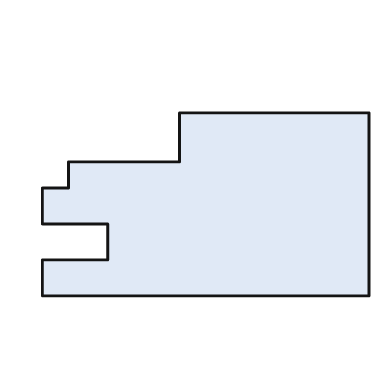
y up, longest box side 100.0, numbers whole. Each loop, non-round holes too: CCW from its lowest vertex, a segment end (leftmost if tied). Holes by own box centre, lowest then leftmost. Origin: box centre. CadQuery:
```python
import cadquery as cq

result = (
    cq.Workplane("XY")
    .moveTo(-50.0, -28.0)
    .lineTo(50.0, -28.0)
    .lineTo(50.0, 28.0)
    .lineTo(-8.0, 28.0)
    .lineTo(-8.0, 13.0)
    .lineTo(-42.0, 13.0)
    .lineTo(-42.0, 5.0)
    .lineTo(-50.0, 5.0)
    .lineTo(-50.0, -6.0)
    .lineTo(-30.0, -6.0)
    .lineTo(-30.0, -17.0)
    .lineTo(-50.0, -17.0)
    .close()
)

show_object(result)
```